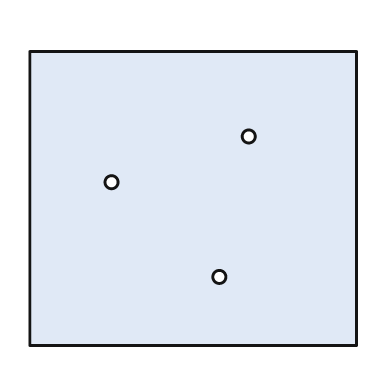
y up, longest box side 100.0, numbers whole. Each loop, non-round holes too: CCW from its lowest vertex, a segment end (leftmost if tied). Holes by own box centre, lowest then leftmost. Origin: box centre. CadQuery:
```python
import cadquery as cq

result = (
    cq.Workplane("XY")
    .moveTo(-50.0, -45.0)
    .lineTo(50.0, -45.0)
    .lineTo(50.0, 45.0)
    .lineTo(-50.0, 45.0)
    .close()
    .moveTo(8.0, -24.0)
    .circle(2.0)
    .moveTo(-25.0, 5.0)
    .circle(2.0)
    .moveTo(17.0, 19.0)
    .circle(2.0)
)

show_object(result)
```